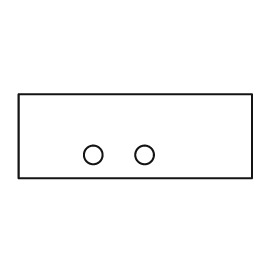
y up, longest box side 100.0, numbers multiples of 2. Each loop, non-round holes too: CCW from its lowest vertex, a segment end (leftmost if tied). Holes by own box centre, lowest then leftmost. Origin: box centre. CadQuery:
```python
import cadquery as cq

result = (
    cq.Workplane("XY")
    .moveTo(-50.0, -18.0)
    .lineTo(50.0, -18.0)
    .lineTo(50.0, 18.0)
    .lineTo(-50.0, 18.0)
    .close()
    .moveTo(-18.0, -8.0)
    .circle(4.0)
    .moveTo(4.0, -8.0)
    .circle(4.0)
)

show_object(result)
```